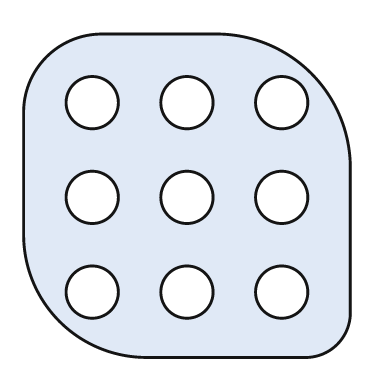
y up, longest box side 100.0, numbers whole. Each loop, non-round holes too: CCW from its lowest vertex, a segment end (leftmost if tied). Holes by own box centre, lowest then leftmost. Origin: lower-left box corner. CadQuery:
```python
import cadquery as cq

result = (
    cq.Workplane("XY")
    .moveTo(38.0, 0.0)
    .lineTo(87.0, 0.0)
    .threePointArc((96.0, 4.0), (100.0, 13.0))
    .lineTo(100.0, 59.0)
    .threePointArc((88.0, 87.0), (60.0, 99.0))
    .lineTo(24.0, 99.0)
    .threePointArc((7.0, 92.0), (0.0, 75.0))
    .lineTo(0.0, 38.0)
    .threePointArc((11.0, 11.0), (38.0, 0.0))
    .close()
    .moveTo(21.0, 20.0)
    .circle(8.0)
    .moveTo(50.0, 20.0)
    .circle(8.0)
    .moveTo(79.0, 20.0)
    .circle(8.0)
    .moveTo(21.0, 49.0)
    .circle(8.0)
    .moveTo(50.0, 49.0)
    .circle(8.0)
    .moveTo(79.0, 49.0)
    .circle(8.0)
    .moveTo(21.0, 78.0)
    .circle(8.0)
    .moveTo(50.0, 78.0)
    .circle(8.0)
    .moveTo(79.0, 78.0)
    .circle(8.0)
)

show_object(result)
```